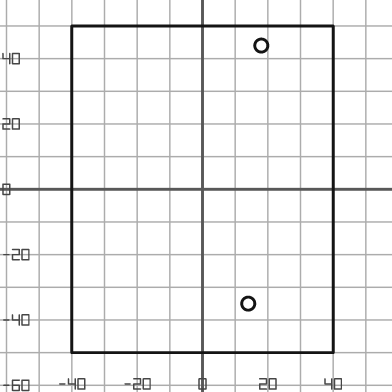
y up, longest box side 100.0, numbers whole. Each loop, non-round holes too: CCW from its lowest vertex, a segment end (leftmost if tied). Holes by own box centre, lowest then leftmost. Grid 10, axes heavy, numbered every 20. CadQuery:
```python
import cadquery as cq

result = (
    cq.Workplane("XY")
    .moveTo(-40.0, -50.0)
    .lineTo(40.0, -50.0)
    .lineTo(40.0, 50.0)
    .lineTo(-40.0, 50.0)
    .close()
    .moveTo(14.0, -35.0)
    .circle(2.0)
    .moveTo(18.0, 44.0)
    .circle(2.0)
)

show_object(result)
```